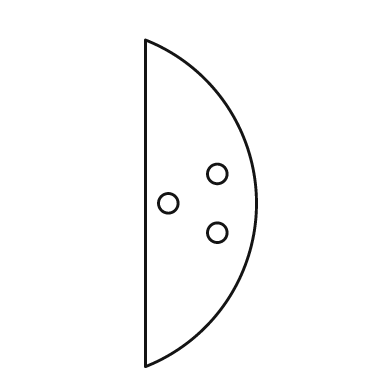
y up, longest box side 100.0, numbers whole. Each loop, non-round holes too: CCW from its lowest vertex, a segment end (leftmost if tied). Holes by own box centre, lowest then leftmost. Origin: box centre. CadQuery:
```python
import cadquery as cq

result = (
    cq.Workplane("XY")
    .moveTo(-17.0, -50.0)
    .threePointArc((17.0, 0.0), (-17.0, 50.0))
    .close()
    .moveTo(5.0, -9.0)
    .circle(3.0)
    .moveTo(-10.0, 0.0)
    .circle(3.0)
    .moveTo(5.0, 9.0)
    .circle(3.0)
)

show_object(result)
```